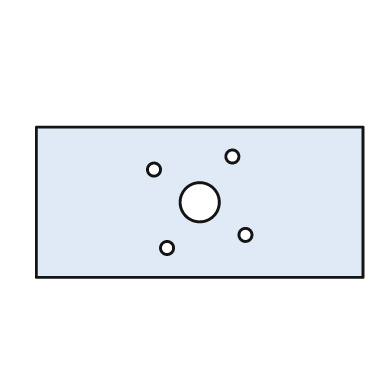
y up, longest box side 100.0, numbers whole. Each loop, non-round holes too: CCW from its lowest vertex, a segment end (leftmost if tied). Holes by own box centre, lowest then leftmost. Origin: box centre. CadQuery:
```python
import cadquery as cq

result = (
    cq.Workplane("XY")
    .moveTo(-50.0, -23.0)
    .lineTo(50.0, -23.0)
    .lineTo(50.0, 23.0)
    .lineTo(-50.0, 23.0)
    .close()
    .moveTo(-10.0, -14.0)
    .circle(2.0)
    .moveTo(14.0, -10.0)
    .circle(2.0)
    .moveTo(0.0, 0.0)
    .circle(6.0)
    .moveTo(-14.0, 10.0)
    .circle(2.0)
    .moveTo(10.0, 14.0)
    .circle(2.0)
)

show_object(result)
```